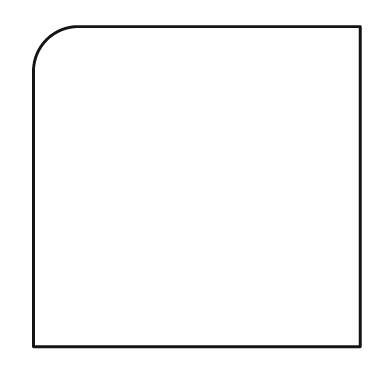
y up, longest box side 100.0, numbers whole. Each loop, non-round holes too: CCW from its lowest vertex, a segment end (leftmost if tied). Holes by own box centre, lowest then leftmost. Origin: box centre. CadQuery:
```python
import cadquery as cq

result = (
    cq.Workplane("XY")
    .moveTo(-50.0, -49.0)
    .lineTo(50.0, -49.0)
    .lineTo(50.0, 49.0)
    .lineTo(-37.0, 49.0)
    .threePointArc((-46.0, 45.0), (-50.0, 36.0))
    .close()
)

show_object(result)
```